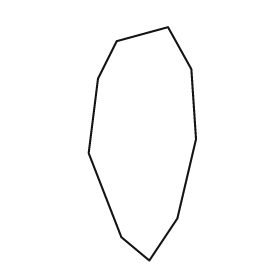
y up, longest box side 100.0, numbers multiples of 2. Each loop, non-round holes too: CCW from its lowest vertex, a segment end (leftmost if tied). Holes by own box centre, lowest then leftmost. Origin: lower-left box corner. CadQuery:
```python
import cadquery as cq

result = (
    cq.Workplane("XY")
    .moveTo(26.0, 0.0)
    .lineTo(38.0, 18.0)
    .lineTo(46.0, 52.0)
    .lineTo(44.0, 82.0)
    .lineTo(34.0, 100.0)
    .lineTo(12.0, 94.0)
    .lineTo(4.0, 78.0)
    .lineTo(0.0, 46.0)
    .lineTo(14.0, 10.0)
    .close()
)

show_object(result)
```